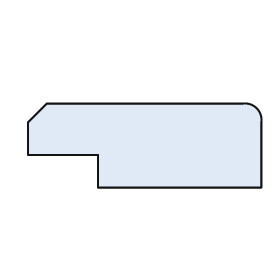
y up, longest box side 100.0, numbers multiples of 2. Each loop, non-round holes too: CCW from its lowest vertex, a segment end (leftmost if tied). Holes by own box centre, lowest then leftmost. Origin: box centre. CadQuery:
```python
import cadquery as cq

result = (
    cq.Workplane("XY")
    .moveTo(-20.0, -18.0)
    .lineTo(50.0, -18.0)
    .lineTo(50.0, 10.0)
    .threePointArc((48.0, 16.0), (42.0, 18.0))
    .lineTo(-42.0, 18.0)
    .lineTo(-50.0, 10.0)
    .lineTo(-50.0, -4.0)
    .lineTo(-20.0, -4.0)
    .close()
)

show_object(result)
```